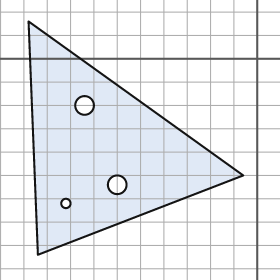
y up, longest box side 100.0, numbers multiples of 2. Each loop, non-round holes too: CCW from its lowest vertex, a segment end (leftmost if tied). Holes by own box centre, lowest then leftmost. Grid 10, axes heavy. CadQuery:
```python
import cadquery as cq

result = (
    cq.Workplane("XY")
    .moveTo(-94.0, -84.0)
    .lineTo(-6.0, -50.0)
    .lineTo(-98.0, 16.0)
    .close()
    .moveTo(-82.0, -62.0)
    .circle(2.0)
    .moveTo(-60.0, -54.0)
    .circle(4.0)
    .moveTo(-74.0, -20.0)
    .circle(4.0)
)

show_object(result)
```